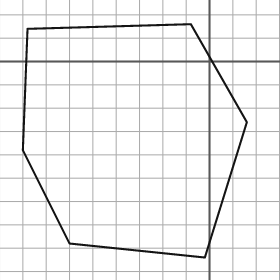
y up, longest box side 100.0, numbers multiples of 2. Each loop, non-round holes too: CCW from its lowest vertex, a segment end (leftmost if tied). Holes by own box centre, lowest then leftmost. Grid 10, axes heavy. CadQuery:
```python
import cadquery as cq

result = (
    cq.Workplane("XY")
    .moveTo(-2.0, -84.0)
    .lineTo(16.0, -26.0)
    .lineTo(-8.0, 16.0)
    .lineTo(-78.0, 14.0)
    .lineTo(-80.0, -38.0)
    .lineTo(-60.0, -78.0)
    .close()
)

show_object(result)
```